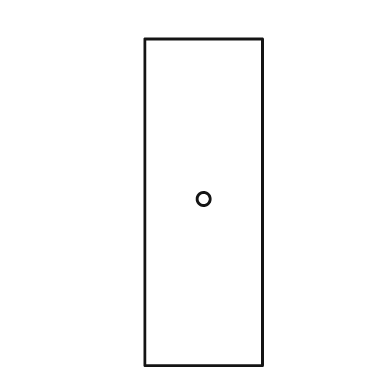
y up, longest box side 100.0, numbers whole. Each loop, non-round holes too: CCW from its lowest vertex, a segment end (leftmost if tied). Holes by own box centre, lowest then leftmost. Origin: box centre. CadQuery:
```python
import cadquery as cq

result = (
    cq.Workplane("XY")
    .moveTo(-18.0, -50.0)
    .lineTo(18.0, -50.0)
    .lineTo(18.0, 50.0)
    .lineTo(-18.0, 50.0)
    .close()
    .moveTo(0.0, 1.0)
    .circle(2.0)
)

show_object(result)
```